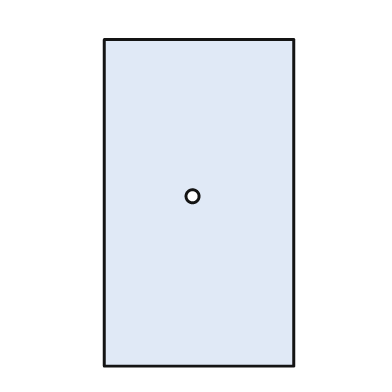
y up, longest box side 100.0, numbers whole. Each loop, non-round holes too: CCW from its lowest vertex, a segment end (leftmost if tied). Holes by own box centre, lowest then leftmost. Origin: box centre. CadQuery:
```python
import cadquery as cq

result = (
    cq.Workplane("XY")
    .moveTo(-29.0, -50.0)
    .lineTo(29.0, -50.0)
    .lineTo(29.0, 50.0)
    .lineTo(-29.0, 50.0)
    .close()
    .moveTo(-2.0, 2.0)
    .circle(2.0)
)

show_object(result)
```